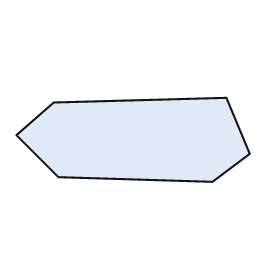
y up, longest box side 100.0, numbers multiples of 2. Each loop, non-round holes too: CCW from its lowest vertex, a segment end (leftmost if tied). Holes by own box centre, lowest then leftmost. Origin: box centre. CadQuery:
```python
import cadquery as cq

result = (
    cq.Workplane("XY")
    .moveTo(34.0, -18.0)
    .lineTo(50.0, -6.0)
    .lineTo(40.0, 18.0)
    .lineTo(-34.0, 16.0)
    .lineTo(-50.0, 2.0)
    .lineTo(-32.0, -16.0)
    .close()
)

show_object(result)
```